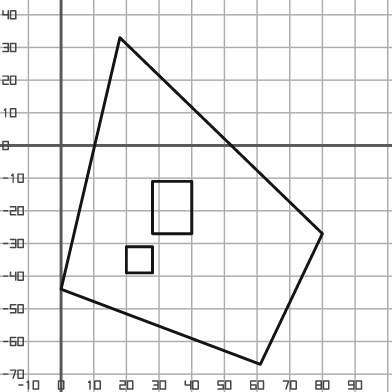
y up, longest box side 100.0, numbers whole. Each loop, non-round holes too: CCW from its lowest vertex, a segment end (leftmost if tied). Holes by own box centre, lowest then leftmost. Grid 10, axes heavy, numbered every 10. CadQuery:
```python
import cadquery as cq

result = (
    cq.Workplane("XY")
    .moveTo(61.0, -67.0)
    .lineTo(80.0, -27.0)
    .lineTo(18.0, 33.0)
    .lineTo(0.0, -44.0)
    .close()
    .moveTo(20.0, -39.0)
    .lineTo(28.0, -39.0)
    .lineTo(28.0, -31.0)
    .lineTo(20.0, -31.0)
    .close()
    .moveTo(28.0, -27.0)
    .lineTo(40.0, -27.0)
    .lineTo(40.0, -11.0)
    .lineTo(28.0, -11.0)
    .close()
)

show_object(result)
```